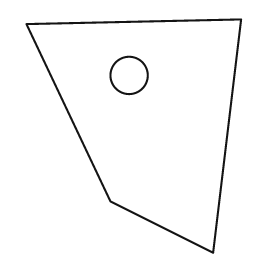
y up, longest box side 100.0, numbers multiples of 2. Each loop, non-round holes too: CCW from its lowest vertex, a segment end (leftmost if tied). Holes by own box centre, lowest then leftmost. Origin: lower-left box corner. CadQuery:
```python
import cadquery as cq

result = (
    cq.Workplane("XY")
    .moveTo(80.0, 0.0)
    .lineTo(92.0, 100.0)
    .lineTo(0.0, 98.0)
    .lineTo(36.0, 22.0)
    .close()
    .moveTo(44.0, 76.0)
    .circle(8.0)
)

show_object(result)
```